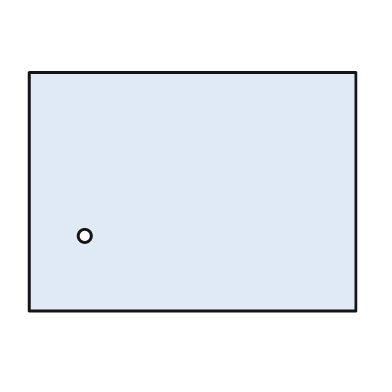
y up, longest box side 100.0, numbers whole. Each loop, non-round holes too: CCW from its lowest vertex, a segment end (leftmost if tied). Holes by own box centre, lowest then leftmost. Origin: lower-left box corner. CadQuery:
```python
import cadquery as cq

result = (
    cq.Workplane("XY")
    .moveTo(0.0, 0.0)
    .lineTo(100.0, 0.0)
    .lineTo(100.0, 73.0)
    .lineTo(0.0, 73.0)
    .close()
    .moveTo(17.0, 23.0)
    .circle(2.0)
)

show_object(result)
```